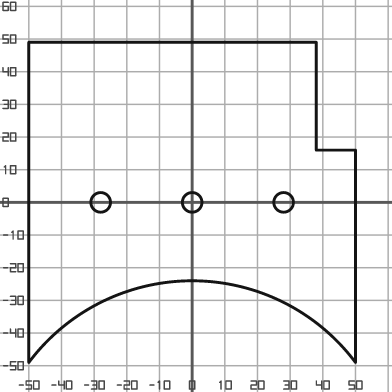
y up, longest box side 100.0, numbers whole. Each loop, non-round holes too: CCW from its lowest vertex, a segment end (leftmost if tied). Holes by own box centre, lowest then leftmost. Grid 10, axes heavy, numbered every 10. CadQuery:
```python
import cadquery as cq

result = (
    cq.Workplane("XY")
    .moveTo(-50.0, -49.0)
    .threePointArc((0.0, -24.0), (50.0, -49.0))
    .lineTo(50.0, 16.0)
    .lineTo(38.0, 16.0)
    .lineTo(38.0, 49.0)
    .lineTo(-50.0, 49.0)
    .close()
    .moveTo(-28.0, 0.0)
    .circle(3.0)
    .moveTo(0.0, 0.0)
    .circle(3.0)
    .moveTo(28.0, 0.0)
    .circle(3.0)
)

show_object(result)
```